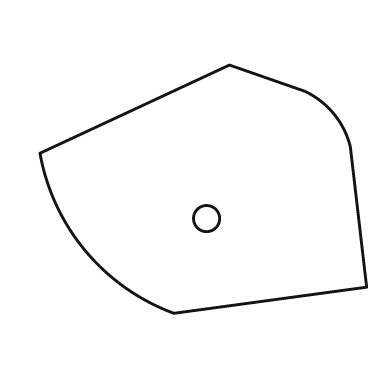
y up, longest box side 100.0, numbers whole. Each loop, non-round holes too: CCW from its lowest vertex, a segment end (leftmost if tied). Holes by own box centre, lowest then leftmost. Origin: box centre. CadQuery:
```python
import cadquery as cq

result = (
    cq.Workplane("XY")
    .moveTo(-9.0, -38.0)
    .lineTo(50.0, -30.0)
    .lineTo(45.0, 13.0)
    .threePointArc((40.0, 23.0), (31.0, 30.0))
    .lineTo(8.0, 38.0)
    .lineTo(-50.0, 11.0)
    .threePointArc((-36.0, -19.0), (-9.0, -38.0))
    .close()
    .moveTo(1.0, -9.0)
    .circle(4.0)
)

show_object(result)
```